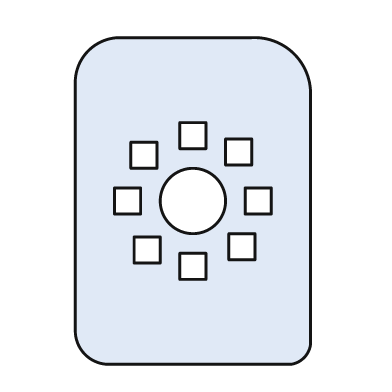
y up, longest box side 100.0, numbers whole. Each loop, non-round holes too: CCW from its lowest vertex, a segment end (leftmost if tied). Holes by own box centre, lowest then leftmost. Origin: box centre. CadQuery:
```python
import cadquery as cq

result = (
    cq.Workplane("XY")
    .moveTo(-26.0, -50.0)
    .lineTo(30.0, -50.0)
    .threePointArc((34.0, -48.0), (36.0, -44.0))
    .lineTo(36.0, 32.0)
    .threePointArc((31.0, 45.0), (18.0, 50.0))
    .lineTo(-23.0, 50.0)
    .threePointArc((-32.0, 46.0), (-36.0, 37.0))
    .lineTo(-36.0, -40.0)
    .threePointArc((-33.0, -47.0), (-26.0, -50.0))
    .close()
    .moveTo(-4.0, -24.0)
    .lineTo(4.0, -24.0)
    .lineTo(4.0, -16.0)
    .lineTo(-4.0, -16.0)
    .close()
    .moveTo(-18.0, -19.0)
    .lineTo(-10.0, -19.0)
    .lineTo(-10.0, -11.0)
    .lineTo(-18.0, -11.0)
    .close()
    .moveTo(11.0, -18.0)
    .lineTo(19.0, -18.0)
    .lineTo(19.0, -10.0)
    .lineTo(11.0, -10.0)
    .close()
    .moveTo(-24.0, -4.0)
    .lineTo(-16.0, -4.0)
    .lineTo(-16.0, 4.0)
    .lineTo(-24.0, 4.0)
    .close()
    .moveTo(0.0, 0.0)
    .circle(10.0)
    .moveTo(16.0, -4.0)
    .lineTo(24.0, -4.0)
    .lineTo(24.0, 4.0)
    .lineTo(16.0, 4.0)
    .close()
    .moveTo(-19.0, 10.0)
    .lineTo(-11.0, 10.0)
    .lineTo(-11.0, 18.0)
    .lineTo(-19.0, 18.0)
    .close()
    .moveTo(10.0, 11.0)
    .lineTo(18.0, 11.0)
    .lineTo(18.0, 19.0)
    .lineTo(10.0, 19.0)
    .close()
    .moveTo(-4.0, 16.0)
    .lineTo(4.0, 16.0)
    .lineTo(4.0, 24.0)
    .lineTo(-4.0, 24.0)
    .close()
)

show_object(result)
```